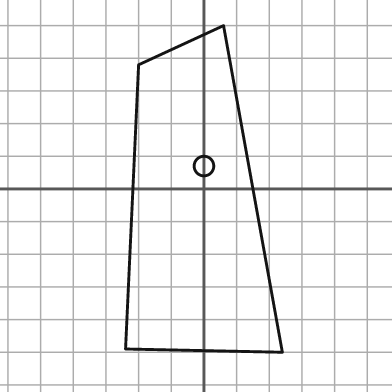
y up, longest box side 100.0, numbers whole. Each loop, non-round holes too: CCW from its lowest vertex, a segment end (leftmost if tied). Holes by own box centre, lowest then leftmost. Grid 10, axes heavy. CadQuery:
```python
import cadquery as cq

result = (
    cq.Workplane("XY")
    .moveTo(24.0, -50.0)
    .lineTo(6.0, 50.0)
    .lineTo(-20.0, 38.0)
    .lineTo(-24.0, -49.0)
    .close()
    .moveTo(0.0, 7.0)
    .circle(3.0)
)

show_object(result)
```